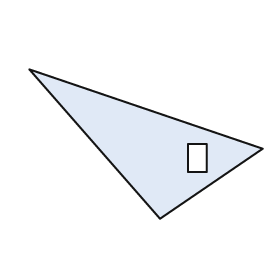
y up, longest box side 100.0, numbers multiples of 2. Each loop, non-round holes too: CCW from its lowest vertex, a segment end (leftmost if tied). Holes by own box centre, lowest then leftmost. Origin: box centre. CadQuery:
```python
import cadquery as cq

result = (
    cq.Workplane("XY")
    .moveTo(6.0, -32.0)
    .lineTo(50.0, -2.0)
    .lineTo(-50.0, 32.0)
    .close()
    .moveTo(18.0, -12.0)
    .lineTo(26.0, -12.0)
    .lineTo(26.0, 0.0)
    .lineTo(18.0, 0.0)
    .close()
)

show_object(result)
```